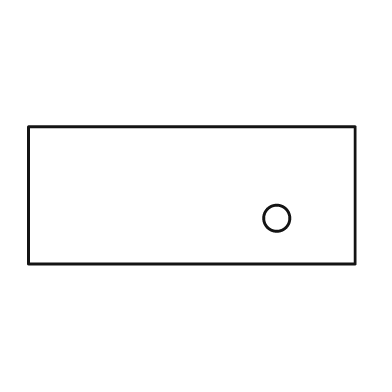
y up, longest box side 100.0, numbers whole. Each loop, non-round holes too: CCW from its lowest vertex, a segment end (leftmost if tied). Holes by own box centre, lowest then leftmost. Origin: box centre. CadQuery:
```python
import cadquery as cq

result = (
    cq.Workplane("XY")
    .moveTo(-50.0, -21.0)
    .lineTo(50.0, -21.0)
    .lineTo(50.0, 21.0)
    .lineTo(-50.0, 21.0)
    .close()
    .moveTo(26.0, -7.0)
    .circle(4.0)
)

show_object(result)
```